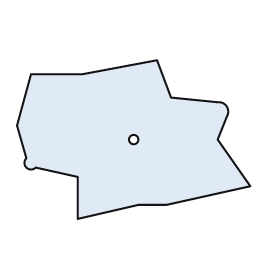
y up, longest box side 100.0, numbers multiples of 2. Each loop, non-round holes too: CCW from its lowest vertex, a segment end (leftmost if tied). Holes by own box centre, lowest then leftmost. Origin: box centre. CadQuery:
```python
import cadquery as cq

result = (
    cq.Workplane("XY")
    .moveTo(-24.0, -34.0)
    .lineTo(2.0, -28.0)
    .lineTo(14.0, -28.0)
    .lineTo(50.0, -20.0)
    .lineTo(36.0, 0.0)
    .lineTo(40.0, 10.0)
    .threePointArc((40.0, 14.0), (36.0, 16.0))
    .lineTo(16.0, 18.0)
    .lineTo(10.0, 34.0)
    .lineTo(-22.0, 28.0)
    .lineTo(-44.0, 28.0)
    .lineTo(-50.0, 6.0)
    .lineTo(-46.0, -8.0)
    .threePointArc((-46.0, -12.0), (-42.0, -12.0))
    .lineTo(-24.0, -16.0)
    .close()
    .moveTo(0.0, 0.0)
    .circle(2.0)
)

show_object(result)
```